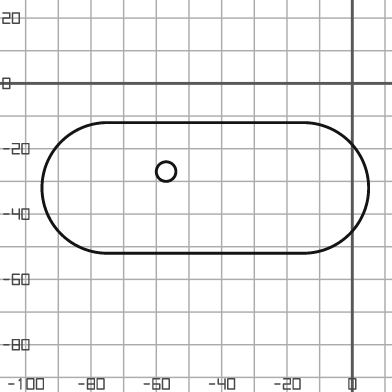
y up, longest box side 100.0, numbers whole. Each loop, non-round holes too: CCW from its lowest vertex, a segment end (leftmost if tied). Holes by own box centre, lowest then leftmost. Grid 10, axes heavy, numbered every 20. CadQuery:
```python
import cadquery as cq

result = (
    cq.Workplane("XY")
    .moveTo(-75.0, -52.0)
    .lineTo(-15.0, -52.0)
    .threePointArc((5.0, -32.0), (-15.0, -12.0))
    .lineTo(-75.0, -12.0)
    .threePointArc((-95.0, -32.0), (-75.0, -52.0))
    .close()
    .moveTo(-57.0, -27.0)
    .circle(3.0)
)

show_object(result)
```